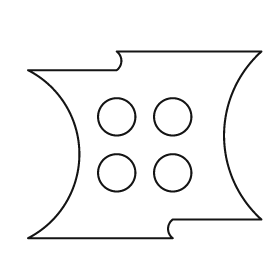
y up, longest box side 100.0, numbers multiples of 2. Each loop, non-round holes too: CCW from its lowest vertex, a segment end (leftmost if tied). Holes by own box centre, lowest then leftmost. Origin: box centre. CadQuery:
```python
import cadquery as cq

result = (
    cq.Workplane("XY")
    .moveTo(-50.0, -40.0)
    .lineTo(12.0, -40.0)
    .threePointArc((10.0, -36.0), (12.0, -32.0))
    .lineTo(50.0, -32.0)
    .threePointArc((34.0, 4.0), (50.0, 40.0))
    .lineTo(-12.0, 40.0)
    .threePointArc((-10.0, 36.0), (-12.0, 32.0))
    .lineTo(-50.0, 32.0)
    .threePointArc((-28.0, -4.0), (-50.0, -40.0))
    .close()
    .moveTo(-12.0, -12.0)
    .circle(8.0)
    .moveTo(12.0, -12.0)
    .circle(8.0)
    .moveTo(-12.0, 12.0)
    .circle(8.0)
    .moveTo(12.0, 12.0)
    .circle(8.0)
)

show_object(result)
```